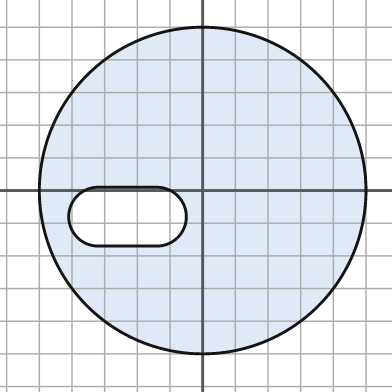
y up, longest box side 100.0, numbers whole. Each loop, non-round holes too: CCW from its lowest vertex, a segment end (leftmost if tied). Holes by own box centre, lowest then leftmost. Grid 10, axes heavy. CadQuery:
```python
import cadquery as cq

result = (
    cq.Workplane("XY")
    .moveTo(0.0, 0.0)
    .circle(50.0)
    .moveTo(-32.0, -17.0)
    .lineTo(-14.0, -17.0)
    .threePointArc((-5.0, -8.0), (-14.0, 1.0))
    .lineTo(-32.0, 1.0)
    .threePointArc((-41.0, -8.0), (-32.0, -17.0))
    .close()
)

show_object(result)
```